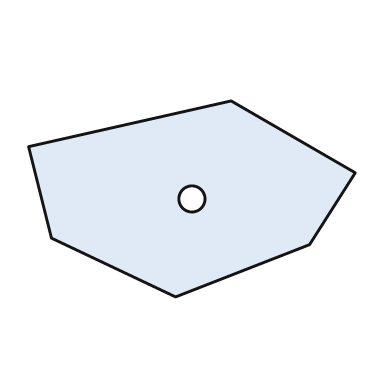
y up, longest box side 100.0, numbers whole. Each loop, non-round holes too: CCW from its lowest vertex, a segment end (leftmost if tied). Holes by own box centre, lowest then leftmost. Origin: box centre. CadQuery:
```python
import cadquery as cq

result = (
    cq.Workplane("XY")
    .moveTo(-5.0, -30.0)
    .lineTo(36.0, -14.0)
    .lineTo(50.0, 8.0)
    .lineTo(12.0, 30.0)
    .lineTo(-50.0, 16.0)
    .lineTo(-43.0, -12.0)
    .close()
    .moveTo(0.0, 0.0)
    .circle(4.0)
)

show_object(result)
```